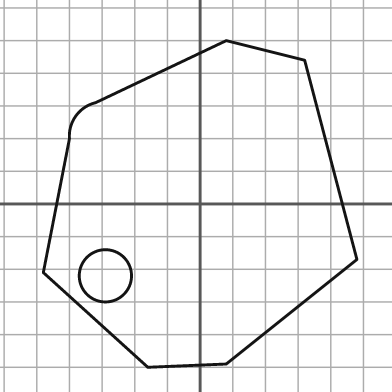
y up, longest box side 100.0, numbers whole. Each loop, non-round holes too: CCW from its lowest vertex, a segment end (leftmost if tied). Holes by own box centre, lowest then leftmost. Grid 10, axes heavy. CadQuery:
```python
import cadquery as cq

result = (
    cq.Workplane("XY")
    .moveTo(-16.0, -50.0)
    .lineTo(8.0, -49.0)
    .lineTo(48.0, -17.0)
    .lineTo(32.0, 44.0)
    .lineTo(8.0, 50.0)
    .lineTo(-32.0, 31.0)
    .threePointArc((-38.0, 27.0), (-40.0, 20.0))
    .lineTo(-48.0, -21.0)
    .close()
    .moveTo(-29.0, -22.0)
    .circle(8.0)
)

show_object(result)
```